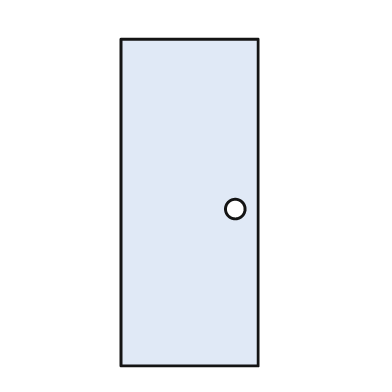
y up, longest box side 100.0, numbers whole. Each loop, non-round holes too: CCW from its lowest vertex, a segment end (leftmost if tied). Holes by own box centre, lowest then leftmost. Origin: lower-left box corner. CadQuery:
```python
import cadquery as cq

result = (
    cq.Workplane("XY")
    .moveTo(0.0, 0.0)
    .lineTo(42.0, 0.0)
    .lineTo(42.0, 100.0)
    .lineTo(0.0, 100.0)
    .close()
    .moveTo(35.0, 48.0)
    .circle(3.0)
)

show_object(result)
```